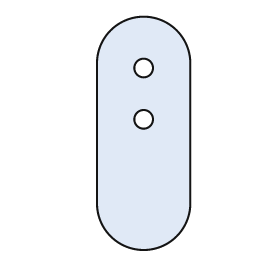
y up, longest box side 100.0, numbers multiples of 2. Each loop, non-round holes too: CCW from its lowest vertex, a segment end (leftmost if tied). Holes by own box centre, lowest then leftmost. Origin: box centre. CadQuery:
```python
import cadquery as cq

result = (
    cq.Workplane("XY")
    .moveTo(-20.0, -30.0)
    .threePointArc((0.0, -50.0), (20.0, -30.0))
    .lineTo(20.0, 30.0)
    .threePointArc((0.0, 50.0), (-20.0, 30.0))
    .close()
    .moveTo(0.0, 6.0)
    .circle(4.0)
    .moveTo(0.0, 28.0)
    .circle(4.0)
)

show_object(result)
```